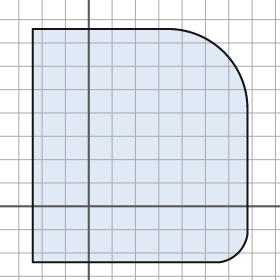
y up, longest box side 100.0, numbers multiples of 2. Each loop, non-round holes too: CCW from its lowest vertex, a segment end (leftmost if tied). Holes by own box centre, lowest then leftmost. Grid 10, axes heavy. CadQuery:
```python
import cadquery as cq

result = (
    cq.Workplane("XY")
    .moveTo(-24.0, -24.0)
    .lineTo(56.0, -24.0)
    .threePointArc((64.0, -20.0), (68.0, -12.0))
    .lineTo(68.0, 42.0)
    .threePointArc((58.0, 66.0), (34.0, 76.0))
    .lineTo(-24.0, 76.0)
    .close()
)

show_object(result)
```